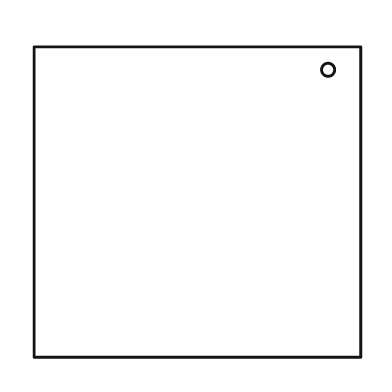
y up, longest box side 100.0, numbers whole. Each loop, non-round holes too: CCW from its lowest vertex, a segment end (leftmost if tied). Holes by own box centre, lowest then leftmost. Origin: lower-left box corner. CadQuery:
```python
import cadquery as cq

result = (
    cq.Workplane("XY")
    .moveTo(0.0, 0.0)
    .lineTo(100.0, 0.0)
    .lineTo(100.0, 95.0)
    .lineTo(0.0, 95.0)
    .close()
    .moveTo(90.0, 88.0)
    .circle(2.0)
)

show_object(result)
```